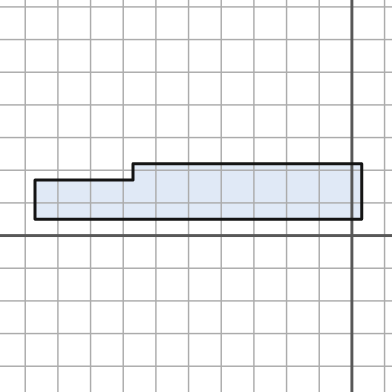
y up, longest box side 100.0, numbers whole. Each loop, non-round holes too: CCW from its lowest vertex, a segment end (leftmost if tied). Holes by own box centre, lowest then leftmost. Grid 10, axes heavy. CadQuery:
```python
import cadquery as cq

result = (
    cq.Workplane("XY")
    .moveTo(-97.0, 5.0)
    .lineTo(3.0, 5.0)
    .lineTo(3.0, 22.0)
    .lineTo(-67.0, 22.0)
    .lineTo(-67.0, 17.0)
    .lineTo(-97.0, 17.0)
    .close()
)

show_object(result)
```